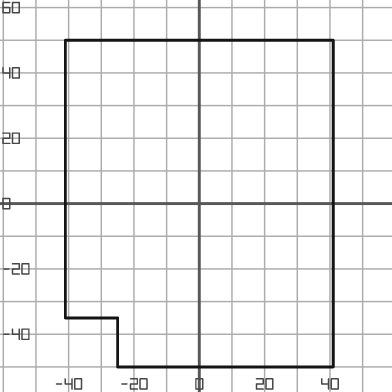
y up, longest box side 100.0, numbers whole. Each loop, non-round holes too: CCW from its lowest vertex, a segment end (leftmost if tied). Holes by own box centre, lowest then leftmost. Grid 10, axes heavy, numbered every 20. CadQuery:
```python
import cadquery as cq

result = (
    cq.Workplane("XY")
    .moveTo(-25.0, -50.0)
    .lineTo(41.0, -50.0)
    .lineTo(41.0, 50.0)
    .lineTo(-41.0, 50.0)
    .lineTo(-41.0, -35.0)
    .lineTo(-25.0, -35.0)
    .close()
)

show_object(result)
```